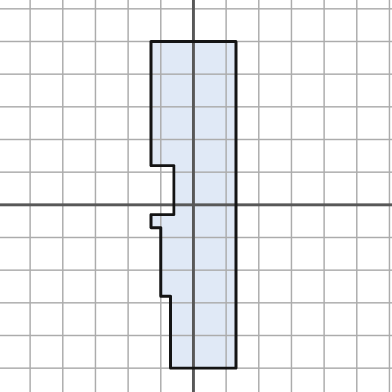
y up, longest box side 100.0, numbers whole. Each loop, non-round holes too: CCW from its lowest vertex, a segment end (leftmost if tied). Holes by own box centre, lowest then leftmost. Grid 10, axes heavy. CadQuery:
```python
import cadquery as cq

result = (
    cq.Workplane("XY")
    .moveTo(-7.0, -50.0)
    .lineTo(13.0, -50.0)
    .lineTo(13.0, 50.0)
    .lineTo(-13.0, 50.0)
    .lineTo(-13.0, 12.0)
    .lineTo(-6.0, 12.0)
    .lineTo(-6.0, -3.0)
    .lineTo(-13.0, -3.0)
    .lineTo(-13.0, -7.0)
    .lineTo(-10.0, -7.0)
    .lineTo(-10.0, -28.0)
    .lineTo(-7.0, -28.0)
    .close()
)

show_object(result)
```